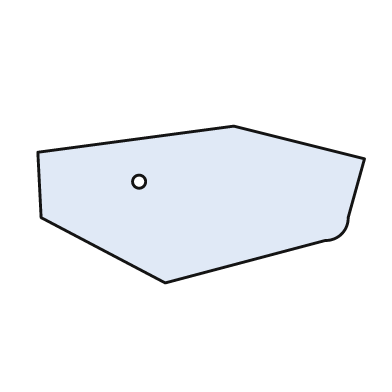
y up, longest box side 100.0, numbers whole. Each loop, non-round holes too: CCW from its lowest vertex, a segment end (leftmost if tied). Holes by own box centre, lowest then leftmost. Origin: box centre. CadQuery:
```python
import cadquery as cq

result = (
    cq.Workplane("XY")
    .moveTo(-11.0, -24.0)
    .lineTo(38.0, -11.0)
    .threePointArc((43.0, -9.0), (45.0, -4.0))
    .lineTo(50.0, 14.0)
    .lineTo(10.0, 24.0)
    .lineTo(-50.0, 16.0)
    .lineTo(-49.0, -4.0)
    .close()
    .moveTo(-19.0, 7.0)
    .circle(2.0)
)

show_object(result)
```